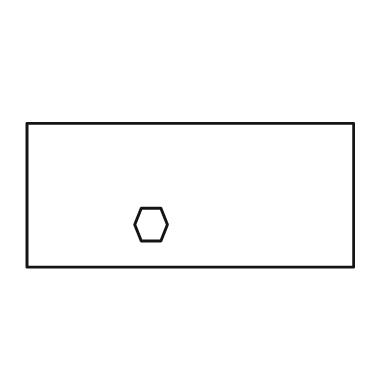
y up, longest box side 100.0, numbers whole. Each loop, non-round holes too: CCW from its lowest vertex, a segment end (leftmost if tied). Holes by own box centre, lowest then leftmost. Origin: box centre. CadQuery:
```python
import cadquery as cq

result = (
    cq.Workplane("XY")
    .moveTo(-50.0, -22.0)
    .lineTo(50.0, -22.0)
    .lineTo(50.0, 22.0)
    .lineTo(-50.0, 22.0)
    .close()
    .moveTo(-15.0, -14.0)
    .lineTo(-9.0, -14.0)
    .lineTo(-7.0, -9.0)
    .lineTo(-9.0, -4.0)
    .lineTo(-15.0, -4.0)
    .lineTo(-17.0, -9.0)
    .close()
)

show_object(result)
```